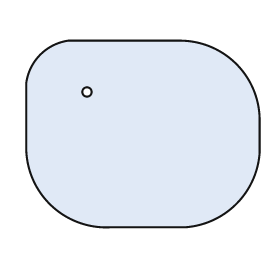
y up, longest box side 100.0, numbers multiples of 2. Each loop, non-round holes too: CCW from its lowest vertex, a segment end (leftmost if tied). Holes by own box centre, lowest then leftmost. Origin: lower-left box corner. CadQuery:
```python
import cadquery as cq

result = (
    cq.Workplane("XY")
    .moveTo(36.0, 0.0)
    .lineTo(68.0, 0.0)
    .threePointArc((90.0, 10.0), (100.0, 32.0))
    .lineTo(100.0, 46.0)
    .threePointArc((90.0, 70.0), (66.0, 80.0))
    .lineTo(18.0, 80.0)
    .threePointArc((6.0, 74.0), (0.0, 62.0))
    .lineTo(0.0, 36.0)
    .threePointArc((10.0, 10.0), (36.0, 0.0))
    .close()
    .moveTo(26.0, 58.0)
    .circle(2.0)
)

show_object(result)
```